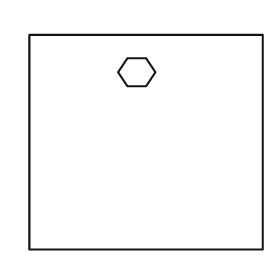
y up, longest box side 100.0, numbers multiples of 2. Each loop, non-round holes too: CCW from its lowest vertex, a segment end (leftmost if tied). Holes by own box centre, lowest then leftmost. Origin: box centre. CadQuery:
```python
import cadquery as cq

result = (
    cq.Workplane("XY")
    .moveTo(-50.0, -46.0)
    .lineTo(50.0, -46.0)
    .lineTo(50.0, 46.0)
    .lineTo(-50.0, 46.0)
    .close()
    .moveTo(-8.0, 24.0)
    .lineTo(0.0, 24.0)
    .lineTo(4.0, 30.0)
    .lineTo(0.0, 36.0)
    .lineTo(-8.0, 36.0)
    .lineTo(-12.0, 30.0)
    .close()
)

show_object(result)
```